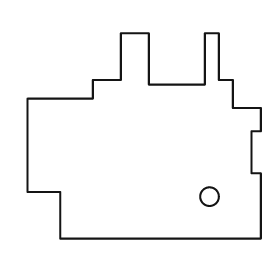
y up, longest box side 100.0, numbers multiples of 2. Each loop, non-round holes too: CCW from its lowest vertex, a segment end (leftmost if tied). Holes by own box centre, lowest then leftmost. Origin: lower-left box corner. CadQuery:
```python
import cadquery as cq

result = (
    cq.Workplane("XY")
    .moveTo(14.0, 0.0)
    .lineTo(100.0, 0.0)
    .lineTo(100.0, 28.0)
    .lineTo(96.0, 28.0)
    .lineTo(96.0, 46.0)
    .lineTo(100.0, 46.0)
    .lineTo(100.0, 56.0)
    .lineTo(88.0, 56.0)
    .lineTo(88.0, 68.0)
    .lineTo(82.0, 68.0)
    .lineTo(82.0, 88.0)
    .lineTo(76.0, 88.0)
    .lineTo(76.0, 66.0)
    .lineTo(52.0, 66.0)
    .lineTo(52.0, 88.0)
    .lineTo(40.0, 88.0)
    .lineTo(40.0, 68.0)
    .lineTo(28.0, 68.0)
    .lineTo(28.0, 60.0)
    .lineTo(0.0, 60.0)
    .lineTo(0.0, 20.0)
    .lineTo(14.0, 20.0)
    .close()
    .moveTo(78.0, 18.0)
    .circle(4.0)
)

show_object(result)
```